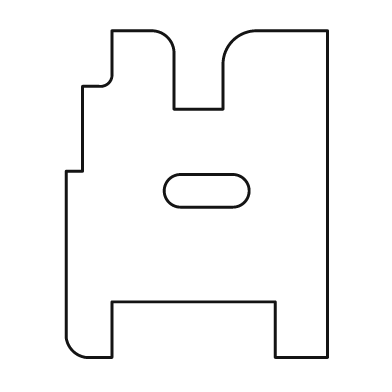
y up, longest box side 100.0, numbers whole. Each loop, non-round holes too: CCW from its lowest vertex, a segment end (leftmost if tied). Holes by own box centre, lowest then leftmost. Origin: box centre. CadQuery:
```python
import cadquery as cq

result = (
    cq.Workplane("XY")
    .moveTo(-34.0, -50.0)
    .lineTo(-26.0, -50.0)
    .lineTo(-26.0, -33.0)
    .lineTo(24.0, -33.0)
    .lineTo(24.0, -50.0)
    .lineTo(40.0, -50.0)
    .lineTo(40.0, 50.0)
    .lineTo(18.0, 50.0)
    .threePointArc((11.0, 47.0), (8.0, 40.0))
    .lineTo(8.0, 26.0)
    .lineTo(-7.0, 26.0)
    .lineTo(-7.0, 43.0)
    .threePointArc((-9.0, 48.0), (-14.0, 50.0))
    .lineTo(-26.0, 50.0)
    .lineTo(-26.0, 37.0)
    .threePointArc((-27.0, 34.0), (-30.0, 33.0))
    .lineTo(-35.0, 33.0)
    .lineTo(-35.0, 7.0)
    .lineTo(-40.0, 7.0)
    .lineTo(-40.0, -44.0)
    .threePointArc((-38.0, -48.0), (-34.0, -50.0))
    .close()
    .moveTo(-5.0, -4.0)
    .lineTo(11.0, -4.0)
    .threePointArc((16.0, 1.0), (11.0, 6.0))
    .lineTo(-5.0, 6.0)
    .threePointArc((-10.0, 1.0), (-5.0, -4.0))
    .close()
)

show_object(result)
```